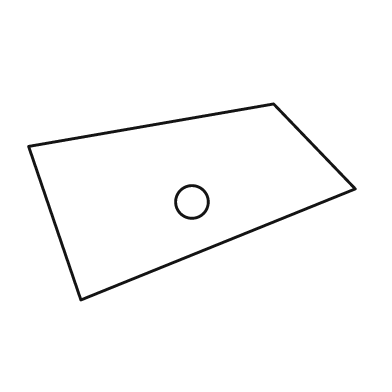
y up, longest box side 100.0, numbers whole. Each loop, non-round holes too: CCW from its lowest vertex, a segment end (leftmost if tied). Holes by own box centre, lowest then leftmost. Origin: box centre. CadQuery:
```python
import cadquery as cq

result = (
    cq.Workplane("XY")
    .moveTo(-34.0, -30.0)
    .lineTo(50.0, 4.0)
    .lineTo(25.0, 30.0)
    .lineTo(-50.0, 17.0)
    .close()
    .moveTo(0.0, 0.0)
    .circle(5.0)
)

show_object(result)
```